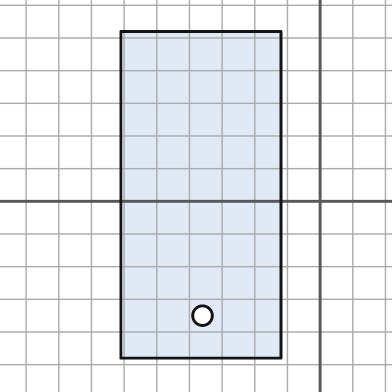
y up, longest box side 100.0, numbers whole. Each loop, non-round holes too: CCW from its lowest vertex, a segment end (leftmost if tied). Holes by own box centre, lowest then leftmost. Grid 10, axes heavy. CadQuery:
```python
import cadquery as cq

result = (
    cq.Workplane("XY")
    .moveTo(-61.0, -48.0)
    .lineTo(-12.0, -48.0)
    .lineTo(-12.0, 52.0)
    .lineTo(-61.0, 52.0)
    .close()
    .moveTo(-36.0, -35.0)
    .circle(3.0)
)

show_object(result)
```